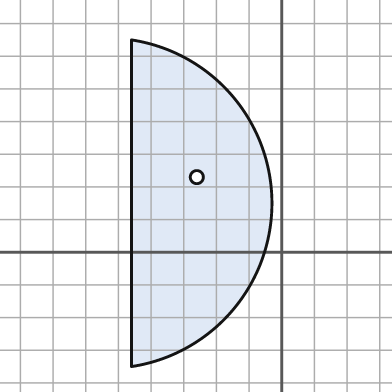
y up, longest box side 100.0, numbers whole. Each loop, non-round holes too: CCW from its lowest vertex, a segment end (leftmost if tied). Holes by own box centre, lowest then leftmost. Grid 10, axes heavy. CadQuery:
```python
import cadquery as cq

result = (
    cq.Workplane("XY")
    .moveTo(-46.0, -35.0)
    .threePointArc((-3.0, 15.0), (-46.0, 65.0))
    .close()
    .moveTo(-26.0, 23.0)
    .circle(2.0)
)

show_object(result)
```